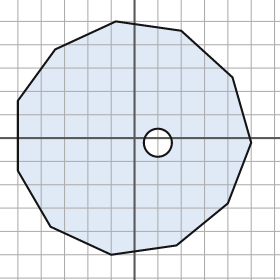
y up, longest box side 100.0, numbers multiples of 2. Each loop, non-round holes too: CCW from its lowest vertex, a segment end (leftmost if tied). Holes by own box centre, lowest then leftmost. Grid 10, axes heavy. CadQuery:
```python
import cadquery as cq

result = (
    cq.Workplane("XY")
    .moveTo(-10.0, -50.0)
    .lineTo(18.0, -46.0)
    .lineTo(40.0, -28.0)
    .lineTo(50.0, -2.0)
    .lineTo(42.0, 26.0)
    .lineTo(20.0, 46.0)
    .lineTo(-8.0, 50.0)
    .lineTo(-34.0, 38.0)
    .lineTo(-50.0, 16.0)
    .lineTo(-50.0, -14.0)
    .lineTo(-36.0, -38.0)
    .close()
    .moveTo(10.0, -2.0)
    .circle(6.0)
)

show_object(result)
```